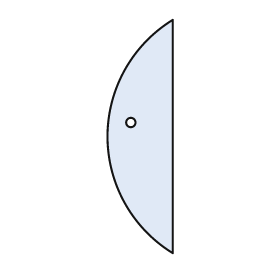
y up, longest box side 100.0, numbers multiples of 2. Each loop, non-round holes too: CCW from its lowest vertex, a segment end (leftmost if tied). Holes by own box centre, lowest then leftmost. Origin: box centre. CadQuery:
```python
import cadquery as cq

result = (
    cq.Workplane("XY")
    .moveTo(14.0, -50.0)
    .lineTo(14.0, 50.0)
    .threePointArc((-14.0, 0.0), (14.0, -50.0))
    .close()
    .moveTo(-4.0, 6.0)
    .circle(2.0)
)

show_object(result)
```